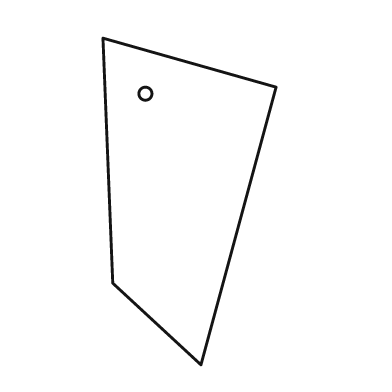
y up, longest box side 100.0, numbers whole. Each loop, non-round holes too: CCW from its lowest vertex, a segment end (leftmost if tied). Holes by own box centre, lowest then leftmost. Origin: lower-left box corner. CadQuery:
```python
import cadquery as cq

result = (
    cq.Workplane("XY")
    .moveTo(30.0, 0.0)
    .lineTo(53.0, 85.0)
    .lineTo(0.0, 100.0)
    .lineTo(3.0, 25.0)
    .close()
    .moveTo(13.0, 83.0)
    .circle(2.0)
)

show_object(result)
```